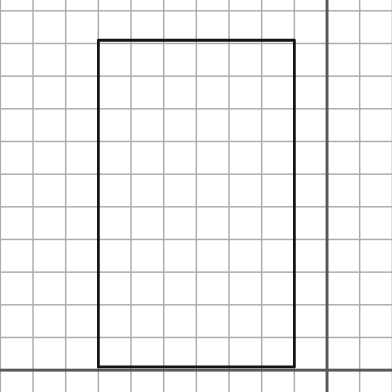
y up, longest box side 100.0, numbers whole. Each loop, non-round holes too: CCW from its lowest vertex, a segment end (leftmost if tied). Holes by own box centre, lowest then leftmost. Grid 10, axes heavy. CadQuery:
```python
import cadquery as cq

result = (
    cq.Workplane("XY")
    .moveTo(-70.0, 1.0)
    .lineTo(-10.0, 1.0)
    .lineTo(-10.0, 101.0)
    .lineTo(-70.0, 101.0)
    .close()
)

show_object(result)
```